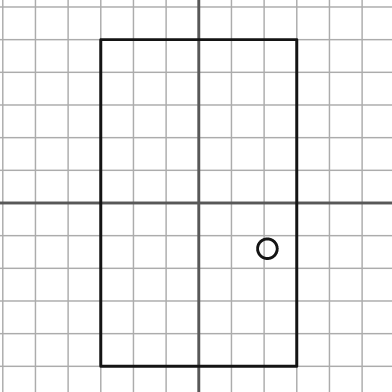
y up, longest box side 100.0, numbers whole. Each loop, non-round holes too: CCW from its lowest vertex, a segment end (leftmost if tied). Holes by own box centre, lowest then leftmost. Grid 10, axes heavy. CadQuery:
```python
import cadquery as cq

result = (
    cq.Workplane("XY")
    .moveTo(-30.0, -50.0)
    .lineTo(30.0, -50.0)
    .lineTo(30.0, 50.0)
    .lineTo(-30.0, 50.0)
    .close()
    .moveTo(21.0, -14.0)
    .circle(3.0)
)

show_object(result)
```